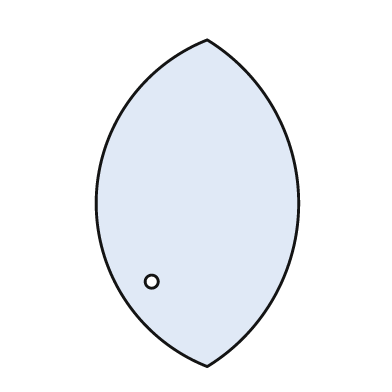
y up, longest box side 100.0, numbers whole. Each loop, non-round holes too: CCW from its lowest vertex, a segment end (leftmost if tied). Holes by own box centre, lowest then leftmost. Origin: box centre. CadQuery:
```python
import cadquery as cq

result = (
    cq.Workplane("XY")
    .moveTo(3.0, -50.0)
    .threePointArc((31.0, 0.0), (3.0, 50.0))
    .threePointArc((-31.0, 0.0), (3.0, -50.0))
    .close()
    .moveTo(-14.0, -24.0)
    .circle(2.0)
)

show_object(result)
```